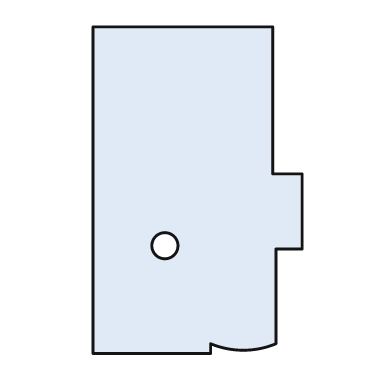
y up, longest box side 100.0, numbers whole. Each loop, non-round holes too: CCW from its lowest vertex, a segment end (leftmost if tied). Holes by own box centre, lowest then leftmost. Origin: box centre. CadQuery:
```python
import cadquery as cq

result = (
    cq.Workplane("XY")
    .moveTo(-32.0, -50.0)
    .lineTo(4.0, -50.0)
    .lineTo(4.0, -47.0)
    .threePointArc((14.0, -49.0), (24.0, -47.0))
    .lineTo(24.0, -18.0)
    .lineTo(32.0, -18.0)
    .lineTo(32.0, 5.0)
    .lineTo(23.0, 5.0)
    .lineTo(23.0, 50.0)
    .lineTo(-32.0, 50.0)
    .close()
    .moveTo(-10.0, -17.0)
    .circle(4.0)
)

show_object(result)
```